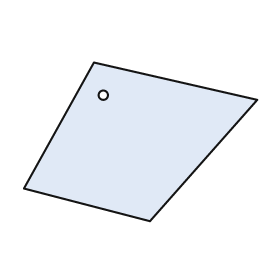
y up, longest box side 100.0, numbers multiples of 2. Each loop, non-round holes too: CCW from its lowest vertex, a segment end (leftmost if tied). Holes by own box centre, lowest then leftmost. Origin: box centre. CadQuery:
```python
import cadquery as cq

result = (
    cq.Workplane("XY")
    .moveTo(4.0, -34.0)
    .lineTo(50.0, 18.0)
    .lineTo(-20.0, 34.0)
    .lineTo(-50.0, -20.0)
    .close()
    .moveTo(-16.0, 20.0)
    .circle(2.0)
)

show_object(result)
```